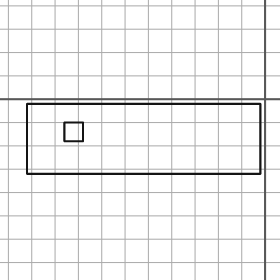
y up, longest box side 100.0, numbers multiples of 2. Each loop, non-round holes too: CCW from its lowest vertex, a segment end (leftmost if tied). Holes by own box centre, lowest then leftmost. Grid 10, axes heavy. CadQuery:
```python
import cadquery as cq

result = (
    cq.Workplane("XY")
    .moveTo(-102.0, -32.0)
    .lineTo(-2.0, -32.0)
    .lineTo(-2.0, -2.0)
    .lineTo(-102.0, -2.0)
    .close()
    .moveTo(-86.0, -18.0)
    .lineTo(-78.0, -18.0)
    .lineTo(-78.0, -10.0)
    .lineTo(-86.0, -10.0)
    .close()
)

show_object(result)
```